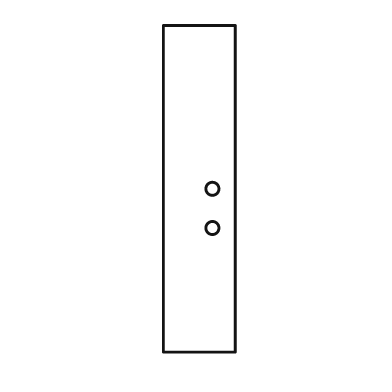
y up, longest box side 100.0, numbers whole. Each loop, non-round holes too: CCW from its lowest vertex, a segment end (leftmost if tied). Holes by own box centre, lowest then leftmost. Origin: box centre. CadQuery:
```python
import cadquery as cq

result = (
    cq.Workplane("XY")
    .moveTo(-11.0, -50.0)
    .lineTo(11.0, -50.0)
    .lineTo(11.0, 50.0)
    .lineTo(-11.0, 50.0)
    .close()
    .moveTo(4.0, -12.0)
    .circle(2.0)
    .moveTo(4.0, 0.0)
    .circle(2.0)
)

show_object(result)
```